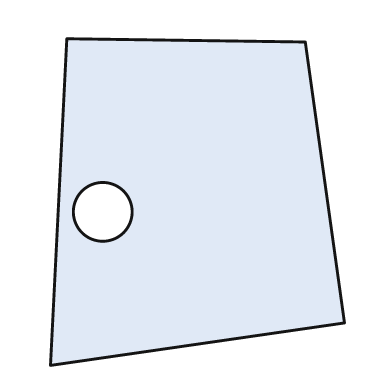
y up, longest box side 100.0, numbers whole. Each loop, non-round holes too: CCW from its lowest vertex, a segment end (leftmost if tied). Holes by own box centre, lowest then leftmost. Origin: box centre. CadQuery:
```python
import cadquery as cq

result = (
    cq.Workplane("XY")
    .moveTo(-45.0, -50.0)
    .lineTo(45.0, -37.0)
    .lineTo(33.0, 49.0)
    .lineTo(-40.0, 50.0)
    .close()
    .moveTo(-29.0, -3.0)
    .circle(9.0)
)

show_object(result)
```